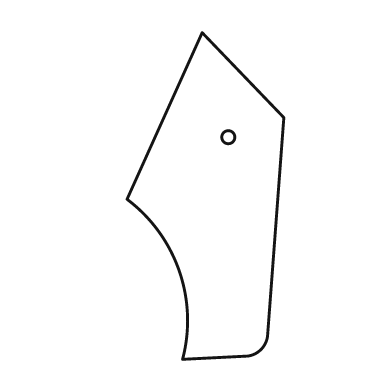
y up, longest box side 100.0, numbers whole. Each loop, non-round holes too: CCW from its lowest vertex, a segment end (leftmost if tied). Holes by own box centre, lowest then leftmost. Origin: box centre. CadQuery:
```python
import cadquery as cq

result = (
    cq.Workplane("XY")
    .moveTo(-7.0, -50.0)
    .lineTo(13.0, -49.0)
    .threePointArc((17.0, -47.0), (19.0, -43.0))
    .lineTo(24.0, 24.0)
    .lineTo(-1.0, 50.0)
    .lineTo(-24.0, -1.0)
    .threePointArc((-8.0, -23.0), (-7.0, -50.0))
    .close()
    .moveTo(7.0, 18.0)
    .circle(2.0)
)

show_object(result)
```